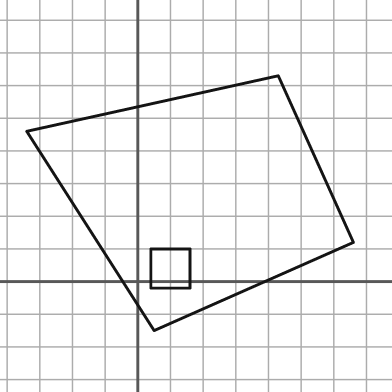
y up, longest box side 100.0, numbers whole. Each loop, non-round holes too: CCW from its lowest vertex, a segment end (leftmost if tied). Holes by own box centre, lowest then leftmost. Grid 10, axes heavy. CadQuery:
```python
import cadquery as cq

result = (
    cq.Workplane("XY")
    .moveTo(5.0, -15.0)
    .lineTo(66.0, 12.0)
    .lineTo(43.0, 63.0)
    .lineTo(-34.0, 46.0)
    .close()
    .moveTo(4.0, -2.0)
    .lineTo(16.0, -2.0)
    .lineTo(16.0, 10.0)
    .lineTo(4.0, 10.0)
    .close()
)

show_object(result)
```